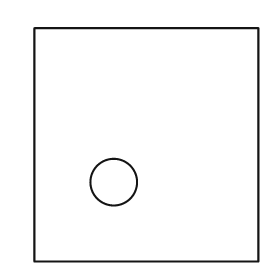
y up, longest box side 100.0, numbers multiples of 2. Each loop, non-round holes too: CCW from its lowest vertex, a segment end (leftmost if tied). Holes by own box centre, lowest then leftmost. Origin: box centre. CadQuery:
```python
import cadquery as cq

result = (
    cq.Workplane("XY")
    .moveTo(-48.0, -50.0)
    .lineTo(48.0, -50.0)
    .lineTo(48.0, 50.0)
    .lineTo(-48.0, 50.0)
    .close()
    .moveTo(-14.0, -16.0)
    .circle(10.0)
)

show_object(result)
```